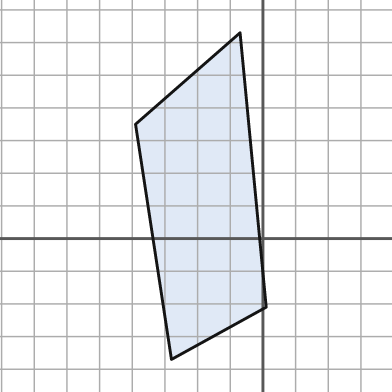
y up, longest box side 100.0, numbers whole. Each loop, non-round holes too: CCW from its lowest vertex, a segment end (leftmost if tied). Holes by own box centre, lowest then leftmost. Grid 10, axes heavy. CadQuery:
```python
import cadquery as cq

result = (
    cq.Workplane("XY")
    .moveTo(-28.0, -37.0)
    .lineTo(1.0, -21.0)
    .lineTo(-7.0, 63.0)
    .lineTo(-39.0, 35.0)
    .close()
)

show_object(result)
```